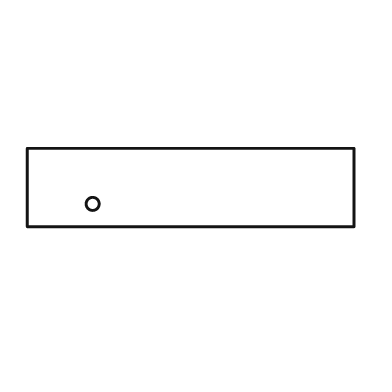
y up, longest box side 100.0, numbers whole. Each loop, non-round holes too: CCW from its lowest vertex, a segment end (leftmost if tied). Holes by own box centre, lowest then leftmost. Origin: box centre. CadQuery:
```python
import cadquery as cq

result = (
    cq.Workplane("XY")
    .moveTo(-50.0, -12.0)
    .lineTo(50.0, -12.0)
    .lineTo(50.0, 12.0)
    .lineTo(-50.0, 12.0)
    .close()
    .moveTo(-30.0, -5.0)
    .circle(2.0)
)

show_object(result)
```